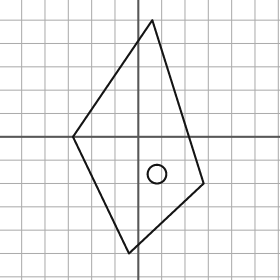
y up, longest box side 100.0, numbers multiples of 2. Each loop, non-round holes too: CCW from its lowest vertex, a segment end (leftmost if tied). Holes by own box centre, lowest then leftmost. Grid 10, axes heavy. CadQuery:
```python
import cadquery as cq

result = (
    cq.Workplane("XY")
    .moveTo(-4.0, -50.0)
    .lineTo(28.0, -20.0)
    .lineTo(6.0, 50.0)
    .lineTo(-28.0, 0.0)
    .close()
    .moveTo(8.0, -16.0)
    .circle(4.0)
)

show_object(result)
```